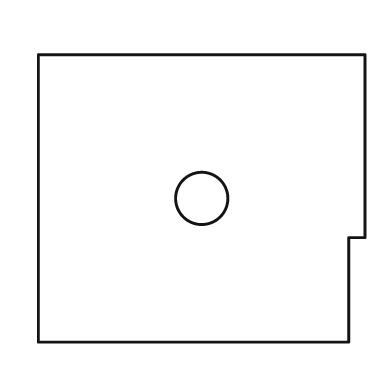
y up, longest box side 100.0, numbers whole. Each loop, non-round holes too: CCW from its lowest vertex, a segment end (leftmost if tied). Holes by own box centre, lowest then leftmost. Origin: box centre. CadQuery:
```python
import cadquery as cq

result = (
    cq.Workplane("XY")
    .moveTo(-50.0, -44.0)
    .lineTo(45.0, -44.0)
    .lineTo(45.0, -12.0)
    .lineTo(50.0, -12.0)
    .lineTo(50.0, 44.0)
    .lineTo(-50.0, 44.0)
    .close()
    .moveTo(0.0, 0.0)
    .circle(8.0)
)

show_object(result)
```